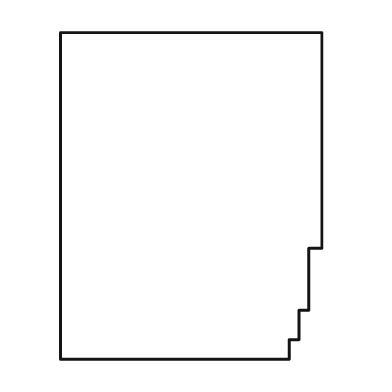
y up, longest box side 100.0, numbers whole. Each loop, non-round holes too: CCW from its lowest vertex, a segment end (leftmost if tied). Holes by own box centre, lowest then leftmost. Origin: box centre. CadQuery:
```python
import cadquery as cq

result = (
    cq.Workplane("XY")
    .moveTo(-40.0, -50.0)
    .lineTo(30.0, -50.0)
    .lineTo(30.0, -44.0)
    .lineTo(33.0, -44.0)
    .lineTo(33.0, -35.0)
    .lineTo(36.0, -35.0)
    .lineTo(36.0, -16.0)
    .lineTo(40.0, -16.0)
    .lineTo(40.0, 50.0)
    .lineTo(-40.0, 50.0)
    .close()
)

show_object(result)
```